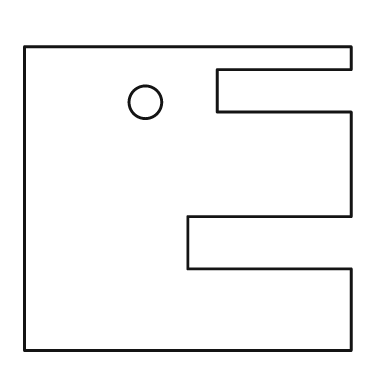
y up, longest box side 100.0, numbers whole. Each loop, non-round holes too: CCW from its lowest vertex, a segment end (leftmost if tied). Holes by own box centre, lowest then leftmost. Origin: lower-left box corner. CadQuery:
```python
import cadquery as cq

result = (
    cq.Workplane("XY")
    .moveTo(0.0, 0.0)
    .lineTo(100.0, 0.0)
    .lineTo(100.0, 25.0)
    .lineTo(50.0, 25.0)
    .lineTo(50.0, 41.0)
    .lineTo(100.0, 41.0)
    .lineTo(100.0, 73.0)
    .lineTo(59.0, 73.0)
    .lineTo(59.0, 86.0)
    .lineTo(100.0, 86.0)
    .lineTo(100.0, 93.0)
    .lineTo(0.0, 93.0)
    .close()
    .moveTo(37.0, 76.0)
    .circle(5.0)
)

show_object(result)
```